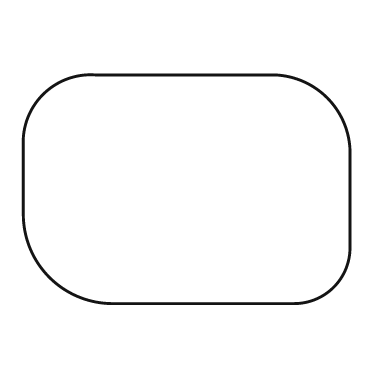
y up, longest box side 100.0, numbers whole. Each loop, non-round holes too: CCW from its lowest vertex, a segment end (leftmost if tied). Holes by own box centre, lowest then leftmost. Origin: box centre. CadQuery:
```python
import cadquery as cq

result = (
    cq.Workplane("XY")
    .moveTo(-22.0, -35.0)
    .lineTo(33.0, -35.0)
    .threePointArc((45.0, -30.0), (50.0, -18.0))
    .lineTo(50.0, 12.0)
    .threePointArc((43.0, 28.0), (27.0, 35.0))
    .lineTo(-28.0, 35.0)
    .threePointArc((-44.0, 29.0), (-50.0, 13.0))
    .lineTo(-50.0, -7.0)
    .threePointArc((-42.0, -27.0), (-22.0, -35.0))
    .close()
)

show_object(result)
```